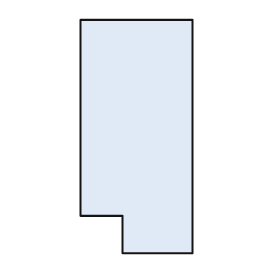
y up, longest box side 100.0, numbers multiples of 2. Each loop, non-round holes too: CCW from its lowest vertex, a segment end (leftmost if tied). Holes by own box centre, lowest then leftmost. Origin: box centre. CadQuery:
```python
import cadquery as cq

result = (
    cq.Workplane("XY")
    .moveTo(-6.0, -50.0)
    .lineTo(24.0, -50.0)
    .lineTo(24.0, 50.0)
    .lineTo(-24.0, 50.0)
    .lineTo(-24.0, -34.0)
    .lineTo(-6.0, -34.0)
    .close()
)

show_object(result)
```